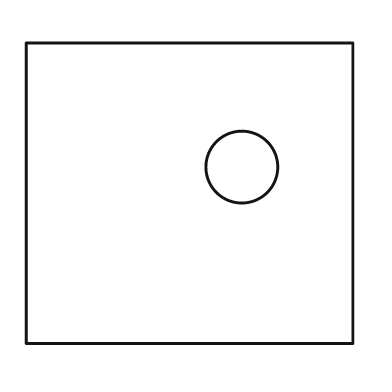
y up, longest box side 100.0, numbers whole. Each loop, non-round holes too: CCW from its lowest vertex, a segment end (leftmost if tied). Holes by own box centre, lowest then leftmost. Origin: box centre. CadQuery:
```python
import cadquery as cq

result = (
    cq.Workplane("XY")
    .moveTo(-50.0, -46.0)
    .lineTo(50.0, -46.0)
    .lineTo(50.0, 46.0)
    .lineTo(-50.0, 46.0)
    .close()
    .moveTo(16.0, 8.0)
    .circle(11.0)
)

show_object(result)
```